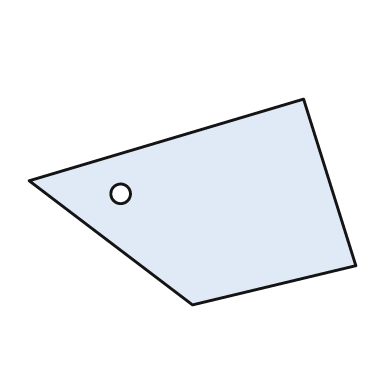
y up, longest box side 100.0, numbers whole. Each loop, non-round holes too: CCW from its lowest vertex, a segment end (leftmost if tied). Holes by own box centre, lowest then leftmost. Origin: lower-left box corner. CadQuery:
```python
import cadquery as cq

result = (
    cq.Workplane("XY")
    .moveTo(50.0, 0.0)
    .lineTo(100.0, 12.0)
    .lineTo(84.0, 63.0)
    .lineTo(0.0, 38.0)
    .close()
    .moveTo(28.0, 34.0)
    .circle(3.0)
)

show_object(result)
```